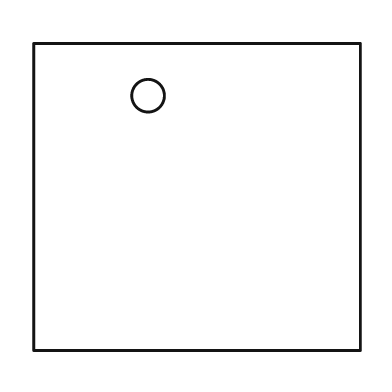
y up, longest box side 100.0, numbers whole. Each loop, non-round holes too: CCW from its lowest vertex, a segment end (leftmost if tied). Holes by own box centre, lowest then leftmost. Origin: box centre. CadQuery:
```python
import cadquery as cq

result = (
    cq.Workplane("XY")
    .moveTo(-50.0, -47.0)
    .lineTo(50.0, -47.0)
    .lineTo(50.0, 47.0)
    .lineTo(-50.0, 47.0)
    .close()
    .moveTo(-15.0, 31.0)
    .circle(5.0)
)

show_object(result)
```